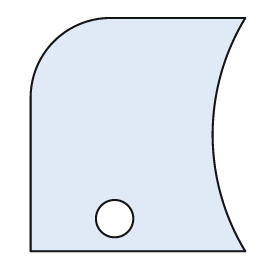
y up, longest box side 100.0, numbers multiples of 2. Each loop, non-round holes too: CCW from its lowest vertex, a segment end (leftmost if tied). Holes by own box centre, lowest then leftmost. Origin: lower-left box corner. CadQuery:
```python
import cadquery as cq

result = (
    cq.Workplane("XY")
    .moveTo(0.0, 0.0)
    .lineTo(92.0, 0.0)
    .threePointArc((78.0, 50.0), (92.0, 100.0))
    .lineTo(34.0, 100.0)
    .threePointArc((10.0, 90.0), (0.0, 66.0))
    .close()
    .moveTo(36.0, 14.0)
    .circle(8.0)
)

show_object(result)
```